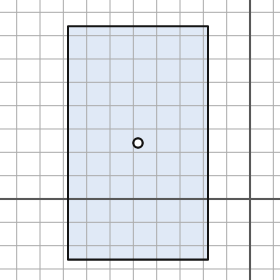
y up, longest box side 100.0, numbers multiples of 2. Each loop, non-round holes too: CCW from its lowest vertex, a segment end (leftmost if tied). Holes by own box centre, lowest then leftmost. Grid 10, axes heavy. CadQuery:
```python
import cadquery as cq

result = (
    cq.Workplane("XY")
    .moveTo(-78.0, -26.0)
    .lineTo(-18.0, -26.0)
    .lineTo(-18.0, 74.0)
    .lineTo(-78.0, 74.0)
    .close()
    .moveTo(-48.0, 24.0)
    .circle(2.0)
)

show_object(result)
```